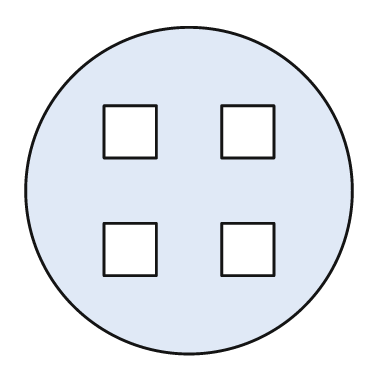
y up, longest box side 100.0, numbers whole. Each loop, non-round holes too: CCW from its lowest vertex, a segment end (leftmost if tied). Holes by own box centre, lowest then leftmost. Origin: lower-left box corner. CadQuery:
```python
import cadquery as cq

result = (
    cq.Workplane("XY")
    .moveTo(50.0, 50.0)
    .circle(50.0)
    .moveTo(24.0, 24.0)
    .lineTo(40.0, 24.0)
    .lineTo(40.0, 40.0)
    .lineTo(24.0, 40.0)
    .close()
    .moveTo(60.0, 24.0)
    .lineTo(76.0, 24.0)
    .lineTo(76.0, 40.0)
    .lineTo(60.0, 40.0)
    .close()
    .moveTo(24.0, 60.0)
    .lineTo(40.0, 60.0)
    .lineTo(40.0, 76.0)
    .lineTo(24.0, 76.0)
    .close()
    .moveTo(60.0, 60.0)
    .lineTo(76.0, 60.0)
    .lineTo(76.0, 76.0)
    .lineTo(60.0, 76.0)
    .close()
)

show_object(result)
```